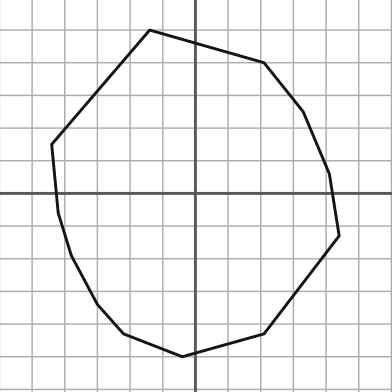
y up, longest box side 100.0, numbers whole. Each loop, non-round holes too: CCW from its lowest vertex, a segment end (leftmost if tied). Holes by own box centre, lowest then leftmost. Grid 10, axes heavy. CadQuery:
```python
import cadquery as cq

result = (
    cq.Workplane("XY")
    .moveTo(-4.0, -50.0)
    .lineTo(21.0, -43.0)
    .lineTo(44.0, -13.0)
    .lineTo(41.0, 6.0)
    .lineTo(33.0, 25.0)
    .lineTo(21.0, 40.0)
    .lineTo(-14.0, 50.0)
    .lineTo(-44.0, 15.0)
    .lineTo(-42.0, -6.0)
    .lineTo(-38.0, -19.0)
    .lineTo(-30.0, -34.0)
    .lineTo(-22.0, -43.0)
    .close()
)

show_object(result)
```